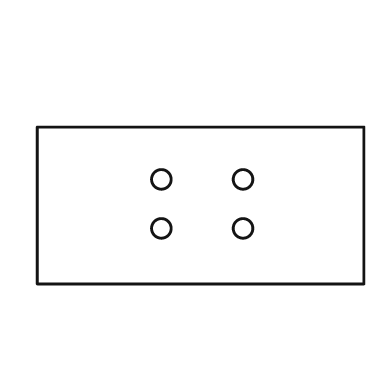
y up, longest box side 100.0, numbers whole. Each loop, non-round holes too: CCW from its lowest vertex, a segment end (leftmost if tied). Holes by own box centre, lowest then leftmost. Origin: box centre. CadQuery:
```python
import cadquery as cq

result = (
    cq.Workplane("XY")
    .moveTo(-50.0, -24.0)
    .lineTo(50.0, -24.0)
    .lineTo(50.0, 24.0)
    .lineTo(-50.0, 24.0)
    .close()
    .moveTo(-12.0, -7.0)
    .circle(3.0)
    .moveTo(13.0, -7.0)
    .circle(3.0)
    .moveTo(-12.0, 8.0)
    .circle(3.0)
    .moveTo(13.0, 8.0)
    .circle(3.0)
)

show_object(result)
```